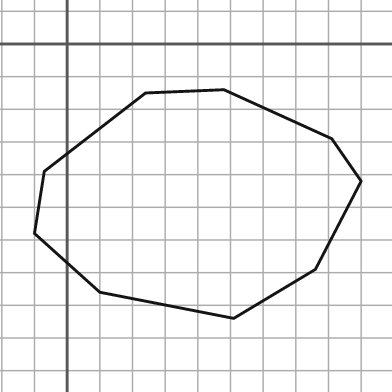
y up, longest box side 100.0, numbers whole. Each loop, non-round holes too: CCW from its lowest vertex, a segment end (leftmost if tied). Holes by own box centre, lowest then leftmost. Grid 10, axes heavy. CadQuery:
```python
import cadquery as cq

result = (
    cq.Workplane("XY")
    .moveTo(51.0, -84.0)
    .lineTo(76.0, -69.0)
    .lineTo(90.0, -42.0)
    .lineTo(81.0, -29.0)
    .lineTo(48.0, -14.0)
    .lineTo(24.0, -15.0)
    .lineTo(-7.0, -39.0)
    .lineTo(-10.0, -58.0)
    .lineTo(10.0, -76.0)
    .close()
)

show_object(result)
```